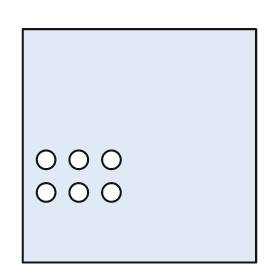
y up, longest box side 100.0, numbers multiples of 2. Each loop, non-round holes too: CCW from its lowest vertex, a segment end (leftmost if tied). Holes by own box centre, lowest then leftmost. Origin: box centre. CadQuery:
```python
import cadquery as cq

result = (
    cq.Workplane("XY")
    .moveTo(-50.0, -50.0)
    .lineTo(50.0, -50.0)
    .lineTo(50.0, 50.0)
    .lineTo(-50.0, 50.0)
    .close()
    .moveTo(-40.0, -20.0)
    .circle(4.0)
    .moveTo(-26.0, -20.0)
    .circle(4.0)
    .moveTo(-12.0, -20.0)
    .circle(4.0)
    .moveTo(-40.0, -6.0)
    .circle(4.0)
    .moveTo(-26.0, -6.0)
    .circle(4.0)
    .moveTo(-12.0, -6.0)
    .circle(4.0)
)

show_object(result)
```